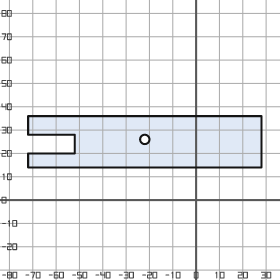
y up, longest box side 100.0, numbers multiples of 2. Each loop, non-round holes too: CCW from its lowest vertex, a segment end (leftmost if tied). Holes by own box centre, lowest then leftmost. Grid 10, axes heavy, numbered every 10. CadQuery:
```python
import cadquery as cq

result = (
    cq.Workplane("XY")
    .moveTo(-72.0, 14.0)
    .lineTo(28.0, 14.0)
    .lineTo(28.0, 36.0)
    .lineTo(-72.0, 36.0)
    .lineTo(-72.0, 28.0)
    .lineTo(-52.0, 28.0)
    .lineTo(-52.0, 20.0)
    .lineTo(-72.0, 20.0)
    .close()
    .moveTo(-22.0, 26.0)
    .circle(2.0)
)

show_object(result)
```